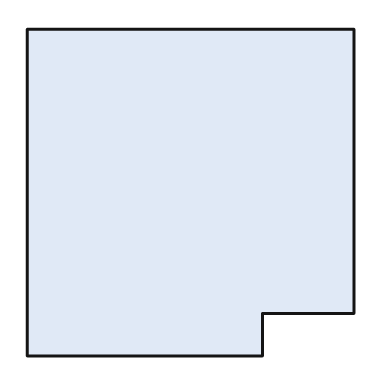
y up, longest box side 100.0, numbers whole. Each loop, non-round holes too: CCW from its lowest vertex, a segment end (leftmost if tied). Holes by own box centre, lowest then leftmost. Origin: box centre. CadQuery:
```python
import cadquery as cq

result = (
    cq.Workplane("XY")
    .moveTo(-50.0, -50.0)
    .lineTo(22.0, -50.0)
    .lineTo(22.0, -37.0)
    .lineTo(50.0, -37.0)
    .lineTo(50.0, 50.0)
    .lineTo(-50.0, 50.0)
    .close()
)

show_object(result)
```